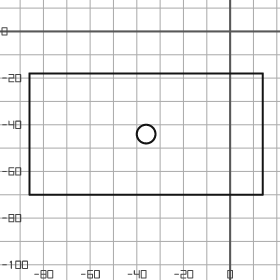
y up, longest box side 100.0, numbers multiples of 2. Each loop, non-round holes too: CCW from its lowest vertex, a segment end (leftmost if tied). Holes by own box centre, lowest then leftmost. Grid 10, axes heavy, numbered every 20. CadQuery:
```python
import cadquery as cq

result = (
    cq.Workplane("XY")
    .moveTo(-86.0, -70.0)
    .lineTo(14.0, -70.0)
    .lineTo(14.0, -18.0)
    .lineTo(-86.0, -18.0)
    .close()
    .moveTo(-36.0, -44.0)
    .circle(4.0)
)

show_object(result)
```